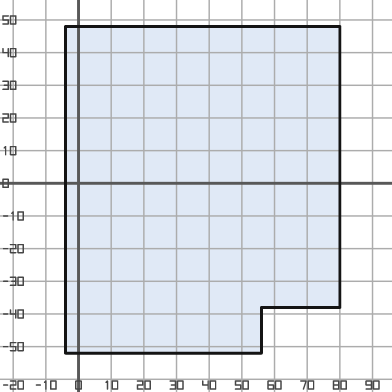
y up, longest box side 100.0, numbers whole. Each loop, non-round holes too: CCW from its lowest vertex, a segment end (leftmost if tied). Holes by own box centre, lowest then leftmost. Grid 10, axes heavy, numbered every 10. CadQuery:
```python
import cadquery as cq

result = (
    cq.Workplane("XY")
    .moveTo(-4.0, -52.0)
    .lineTo(56.0, -52.0)
    .lineTo(56.0, -38.0)
    .lineTo(80.0, -38.0)
    .lineTo(80.0, 48.0)
    .lineTo(-4.0, 48.0)
    .close()
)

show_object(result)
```